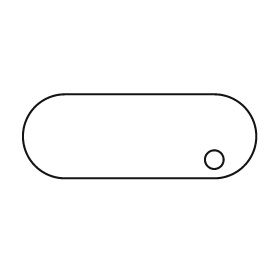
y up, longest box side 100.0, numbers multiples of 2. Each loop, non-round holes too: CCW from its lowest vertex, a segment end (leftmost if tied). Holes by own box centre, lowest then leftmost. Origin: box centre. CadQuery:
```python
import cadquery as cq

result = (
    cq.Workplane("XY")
    .moveTo(-32.0, -18.0)
    .lineTo(32.0, -18.0)
    .threePointArc((50.0, 0.0), (32.0, 18.0))
    .lineTo(-32.0, 18.0)
    .threePointArc((-50.0, 0.0), (-32.0, -18.0))
    .close()
    .moveTo(32.0, -10.0)
    .circle(4.0)
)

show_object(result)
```